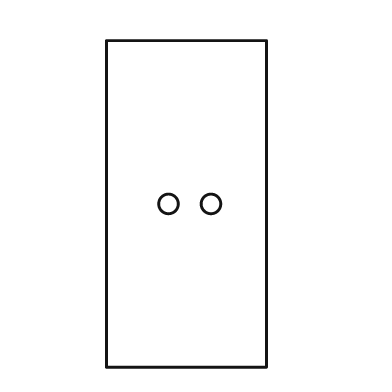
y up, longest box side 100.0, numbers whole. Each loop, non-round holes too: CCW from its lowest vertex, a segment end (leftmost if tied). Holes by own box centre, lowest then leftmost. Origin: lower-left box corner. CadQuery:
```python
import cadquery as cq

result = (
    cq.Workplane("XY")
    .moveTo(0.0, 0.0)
    .lineTo(49.0, 0.0)
    .lineTo(49.0, 100.0)
    .lineTo(0.0, 100.0)
    .close()
    .moveTo(19.0, 50.0)
    .circle(3.0)
    .moveTo(32.0, 50.0)
    .circle(3.0)
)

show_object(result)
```